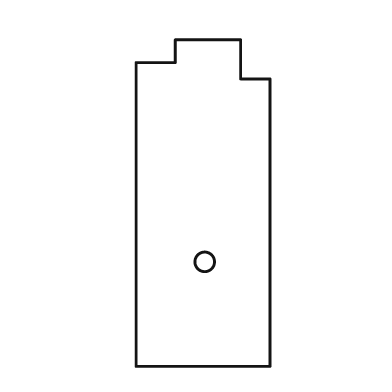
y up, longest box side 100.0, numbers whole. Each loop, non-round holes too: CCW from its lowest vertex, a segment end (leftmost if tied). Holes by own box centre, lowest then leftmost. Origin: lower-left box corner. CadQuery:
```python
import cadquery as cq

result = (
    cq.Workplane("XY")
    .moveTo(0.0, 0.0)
    .lineTo(41.0, 0.0)
    .lineTo(41.0, 88.0)
    .lineTo(32.0, 88.0)
    .lineTo(32.0, 100.0)
    .lineTo(12.0, 100.0)
    .lineTo(12.0, 93.0)
    .lineTo(0.0, 93.0)
    .close()
    .moveTo(21.0, 32.0)
    .circle(3.0)
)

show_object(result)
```